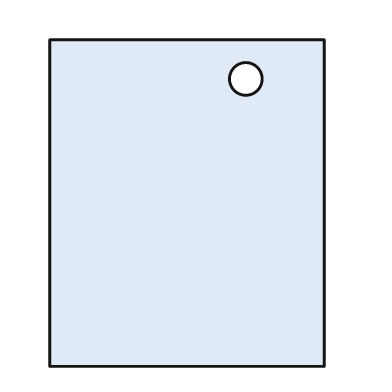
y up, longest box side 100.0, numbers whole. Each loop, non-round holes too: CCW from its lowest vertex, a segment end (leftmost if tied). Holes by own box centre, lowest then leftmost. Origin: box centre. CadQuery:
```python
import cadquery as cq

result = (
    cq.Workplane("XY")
    .moveTo(-42.0, -50.0)
    .lineTo(42.0, -50.0)
    .lineTo(42.0, 50.0)
    .lineTo(-42.0, 50.0)
    .close()
    .moveTo(18.0, 38.0)
    .circle(5.0)
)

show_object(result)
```